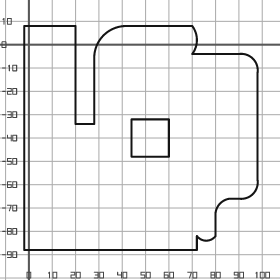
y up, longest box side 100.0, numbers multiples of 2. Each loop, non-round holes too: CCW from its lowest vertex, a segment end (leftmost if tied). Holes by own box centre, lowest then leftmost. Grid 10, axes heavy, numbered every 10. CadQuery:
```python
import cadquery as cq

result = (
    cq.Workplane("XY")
    .moveTo(-2.0, -88.0)
    .lineTo(72.0, -88.0)
    .lineTo(72.0, -82.0)
    .threePointArc((76.0, -84.0), (80.0, -82.0))
    .lineTo(80.0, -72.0)
    .threePointArc((82.0, -68.0), (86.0, -66.0))
    .lineTo(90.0, -66.0)
    .threePointArc((96.0, -64.0), (98.0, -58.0))
    .lineTo(98.0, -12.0)
    .threePointArc((96.0, -6.0), (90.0, -4.0))
    .lineTo(70.0, -4.0)
    .threePointArc((72.0, 2.0), (70.0, 8.0))
    .lineTo(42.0, 8.0)
    .threePointArc((32.0, 4.0), (28.0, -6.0))
    .lineTo(28.0, -34.0)
    .lineTo(20.0, -34.0)
    .lineTo(20.0, 8.0)
    .lineTo(-2.0, 8.0)
    .close()
    .moveTo(44.0, -48.0)
    .lineTo(60.0, -48.0)
    .lineTo(60.0, -32.0)
    .lineTo(44.0, -32.0)
    .close()
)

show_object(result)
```